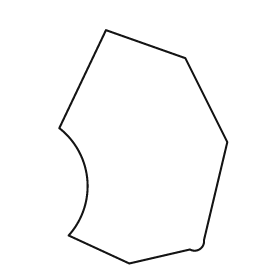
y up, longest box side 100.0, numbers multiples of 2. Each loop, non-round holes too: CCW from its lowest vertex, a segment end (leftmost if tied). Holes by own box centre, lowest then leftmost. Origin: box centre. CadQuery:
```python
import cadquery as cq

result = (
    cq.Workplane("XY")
    .moveTo(-6.0, -50.0)
    .lineTo(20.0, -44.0)
    .threePointArc((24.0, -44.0), (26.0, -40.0))
    .lineTo(36.0, 2.0)
    .lineTo(18.0, 38.0)
    .lineTo(-16.0, 50.0)
    .lineTo(-36.0, 8.0)
    .threePointArc((-24.0, -14.0), (-32.0, -38.0))
    .close()
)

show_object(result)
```